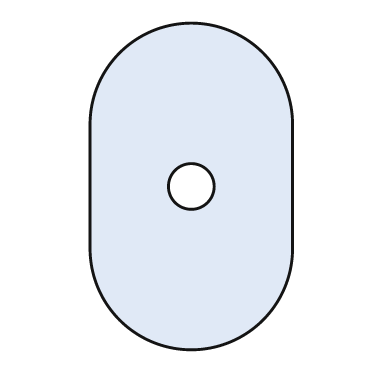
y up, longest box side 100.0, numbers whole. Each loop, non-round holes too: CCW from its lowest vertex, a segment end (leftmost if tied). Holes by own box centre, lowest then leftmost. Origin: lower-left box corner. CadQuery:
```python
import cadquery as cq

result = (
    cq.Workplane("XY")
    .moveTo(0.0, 31.0)
    .threePointArc((31.0, 0.0), (62.0, 31.0))
    .lineTo(62.0, 69.0)
    .threePointArc((31.0, 100.0), (0.0, 69.0))
    .close()
    .moveTo(31.0, 50.0)
    .circle(7.0)
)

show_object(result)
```